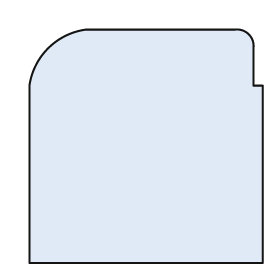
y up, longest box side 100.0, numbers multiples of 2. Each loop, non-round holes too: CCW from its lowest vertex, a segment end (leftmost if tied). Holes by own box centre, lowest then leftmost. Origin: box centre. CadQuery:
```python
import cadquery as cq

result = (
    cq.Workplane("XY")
    .moveTo(-50.0, -50.0)
    .lineTo(50.0, -50.0)
    .lineTo(50.0, 26.0)
    .lineTo(46.0, 26.0)
    .lineTo(46.0, 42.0)
    .threePointArc((44.0, 48.0), (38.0, 50.0))
    .lineTo(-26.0, 50.0)
    .threePointArc((-42.0, 42.0), (-50.0, 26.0))
    .close()
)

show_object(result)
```